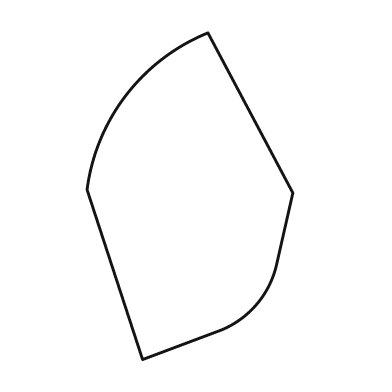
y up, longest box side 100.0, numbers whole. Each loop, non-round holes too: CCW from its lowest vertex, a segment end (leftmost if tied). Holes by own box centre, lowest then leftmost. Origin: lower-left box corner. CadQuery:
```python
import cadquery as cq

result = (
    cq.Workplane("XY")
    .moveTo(17.0, 0.0)
    .lineTo(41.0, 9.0)
    .threePointArc((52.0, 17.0), (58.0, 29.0))
    .lineTo(63.0, 51.0)
    .lineTo(37.0, 100.0)
    .threePointArc((12.0, 81.0), (0.0, 52.0))
    .close()
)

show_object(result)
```